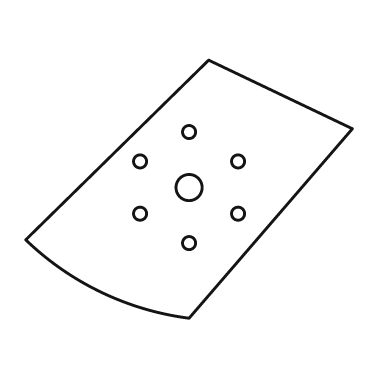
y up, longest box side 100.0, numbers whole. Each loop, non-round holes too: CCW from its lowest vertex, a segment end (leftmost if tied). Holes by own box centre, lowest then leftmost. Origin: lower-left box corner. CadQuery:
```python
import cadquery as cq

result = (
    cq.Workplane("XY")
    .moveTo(50.0, 0.0)
    .lineTo(100.0, 58.0)
    .lineTo(56.0, 79.0)
    .lineTo(0.0, 24.0)
    .threePointArc((23.0, 8.0), (50.0, 0.0))
    .close()
    .moveTo(50.0, 23.0)
    .circle(2.0)
    .moveTo(35.0, 32.0)
    .circle(2.0)
    .moveTo(65.0, 32.0)
    .circle(2.0)
    .moveTo(50.0, 40.0)
    .circle(4.0)
    .moveTo(35.0, 48.0)
    .circle(2.0)
    .moveTo(65.0, 48.0)
    .circle(2.0)
    .moveTo(50.0, 57.0)
    .circle(2.0)
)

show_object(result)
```